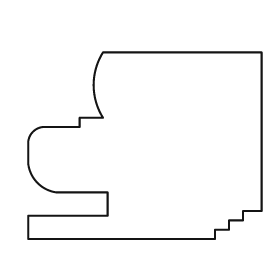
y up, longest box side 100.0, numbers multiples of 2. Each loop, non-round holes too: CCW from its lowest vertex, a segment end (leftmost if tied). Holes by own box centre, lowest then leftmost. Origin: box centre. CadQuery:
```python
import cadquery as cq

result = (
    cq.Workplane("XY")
    .moveTo(-50.0, -40.0)
    .lineTo(30.0, -40.0)
    .lineTo(30.0, -36.0)
    .lineTo(36.0, -36.0)
    .lineTo(36.0, -32.0)
    .lineTo(42.0, -32.0)
    .lineTo(42.0, -28.0)
    .lineTo(50.0, -28.0)
    .lineTo(50.0, 40.0)
    .lineTo(-18.0, 40.0)
    .threePointArc((-22.0, 26.0), (-18.0, 12.0))
    .lineTo(-28.0, 12.0)
    .lineTo(-28.0, 8.0)
    .lineTo(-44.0, 8.0)
    .threePointArc((-48.0, 6.0), (-50.0, 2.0))
    .lineTo(-50.0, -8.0)
    .threePointArc((-46.0, -16.0), (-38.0, -20.0))
    .lineTo(-16.0, -20.0)
    .lineTo(-16.0, -30.0)
    .lineTo(-50.0, -30.0)
    .close()
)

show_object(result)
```